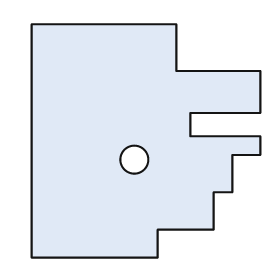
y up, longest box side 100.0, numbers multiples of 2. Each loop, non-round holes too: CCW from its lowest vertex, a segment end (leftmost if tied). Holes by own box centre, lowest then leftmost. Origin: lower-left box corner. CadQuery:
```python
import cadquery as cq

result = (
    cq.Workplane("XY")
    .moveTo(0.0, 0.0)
    .lineTo(54.0, 0.0)
    .lineTo(54.0, 12.0)
    .lineTo(78.0, 12.0)
    .lineTo(78.0, 28.0)
    .lineTo(86.0, 28.0)
    .lineTo(86.0, 44.0)
    .lineTo(98.0, 44.0)
    .lineTo(98.0, 52.0)
    .lineTo(68.0, 52.0)
    .lineTo(68.0, 62.0)
    .lineTo(98.0, 62.0)
    .lineTo(98.0, 80.0)
    .lineTo(62.0, 80.0)
    .lineTo(62.0, 100.0)
    .lineTo(0.0, 100.0)
    .close()
    .moveTo(44.0, 42.0)
    .circle(6.0)
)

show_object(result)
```